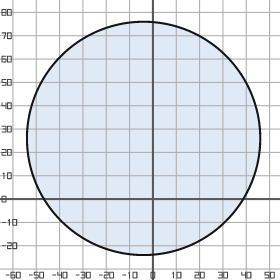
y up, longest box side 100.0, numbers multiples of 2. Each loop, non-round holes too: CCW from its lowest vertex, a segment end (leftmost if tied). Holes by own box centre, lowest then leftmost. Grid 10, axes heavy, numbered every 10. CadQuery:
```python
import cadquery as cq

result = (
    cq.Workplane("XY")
    .moveTo(-4.0, 26.0)
    .circle(50.0)
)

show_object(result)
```